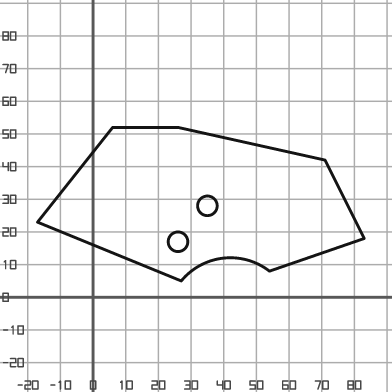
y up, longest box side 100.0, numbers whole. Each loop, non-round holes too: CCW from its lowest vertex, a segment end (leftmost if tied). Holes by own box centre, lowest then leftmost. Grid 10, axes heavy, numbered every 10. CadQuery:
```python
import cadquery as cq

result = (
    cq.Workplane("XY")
    .moveTo(27.0, 5.0)
    .threePointArc((40.0, 12.0), (54.0, 8.0))
    .lineTo(83.0, 18.0)
    .lineTo(71.0, 42.0)
    .lineTo(26.0, 52.0)
    .lineTo(6.0, 52.0)
    .lineTo(-17.0, 23.0)
    .close()
    .moveTo(26.0, 17.0)
    .circle(3.0)
    .moveTo(35.0, 28.0)
    .circle(3.0)
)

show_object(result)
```